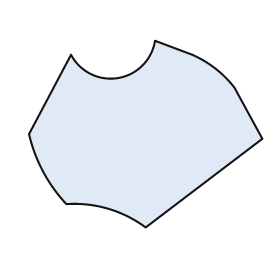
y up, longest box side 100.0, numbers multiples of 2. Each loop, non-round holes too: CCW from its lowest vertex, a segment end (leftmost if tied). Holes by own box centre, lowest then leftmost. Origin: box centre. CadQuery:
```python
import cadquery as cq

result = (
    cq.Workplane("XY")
    .moveTo(0.0, -40.0)
    .lineTo(50.0, -2.0)
    .lineTo(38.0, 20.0)
    .threePointArc((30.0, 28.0), (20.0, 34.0))
    .lineTo(4.0, 40.0)
    .threePointArc((-12.0, 24.0), (-32.0, 34.0))
    .lineTo(-50.0, 0.0)
    .threePointArc((-44.0, -16.0), (-34.0, -30.0))
    .threePointArc((-16.0, -32.0), (0.0, -40.0))
    .close()
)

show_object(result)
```